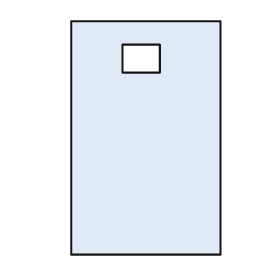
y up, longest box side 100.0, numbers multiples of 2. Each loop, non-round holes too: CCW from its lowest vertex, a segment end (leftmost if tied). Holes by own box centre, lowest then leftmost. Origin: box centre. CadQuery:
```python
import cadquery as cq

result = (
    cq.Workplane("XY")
    .moveTo(-32.0, -50.0)
    .lineTo(32.0, -50.0)
    .lineTo(32.0, 50.0)
    .lineTo(-32.0, 50.0)
    .close()
    .moveTo(-10.0, 28.0)
    .lineTo(6.0, 28.0)
    .lineTo(6.0, 40.0)
    .lineTo(-10.0, 40.0)
    .close()
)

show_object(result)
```